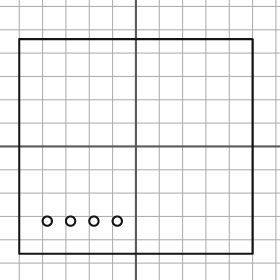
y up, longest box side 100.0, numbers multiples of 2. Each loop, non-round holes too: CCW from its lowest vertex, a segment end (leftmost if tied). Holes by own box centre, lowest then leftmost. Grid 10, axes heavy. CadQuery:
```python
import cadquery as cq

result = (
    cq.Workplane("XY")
    .moveTo(-50.0, -46.0)
    .lineTo(50.0, -46.0)
    .lineTo(50.0, 46.0)
    .lineTo(-50.0, 46.0)
    .close()
    .moveTo(-38.0, -32.0)
    .circle(2.0)
    .moveTo(-28.0, -32.0)
    .circle(2.0)
    .moveTo(-18.0, -32.0)
    .circle(2.0)
    .moveTo(-8.0, -32.0)
    .circle(2.0)
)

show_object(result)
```